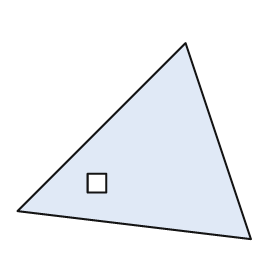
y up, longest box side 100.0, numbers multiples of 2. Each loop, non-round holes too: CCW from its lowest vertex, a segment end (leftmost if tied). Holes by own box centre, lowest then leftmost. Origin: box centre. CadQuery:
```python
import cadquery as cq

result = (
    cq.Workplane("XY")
    .moveTo(50.0, -42.0)
    .lineTo(22.0, 42.0)
    .lineTo(-50.0, -30.0)
    .close()
    .moveTo(-20.0, -22.0)
    .lineTo(-12.0, -22.0)
    .lineTo(-12.0, -14.0)
    .lineTo(-20.0, -14.0)
    .close()
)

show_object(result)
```